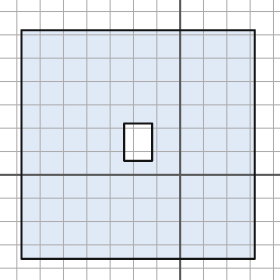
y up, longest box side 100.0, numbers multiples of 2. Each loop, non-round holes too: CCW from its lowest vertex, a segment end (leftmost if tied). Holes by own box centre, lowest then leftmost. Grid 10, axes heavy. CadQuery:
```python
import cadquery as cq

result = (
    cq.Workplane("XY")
    .moveTo(-68.0, -36.0)
    .lineTo(32.0, -36.0)
    .lineTo(32.0, 62.0)
    .lineTo(-68.0, 62.0)
    .close()
    .moveTo(-24.0, 6.0)
    .lineTo(-12.0, 6.0)
    .lineTo(-12.0, 22.0)
    .lineTo(-24.0, 22.0)
    .close()
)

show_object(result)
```